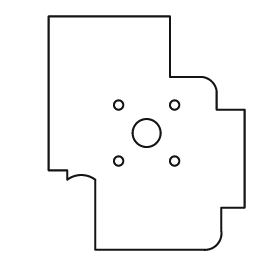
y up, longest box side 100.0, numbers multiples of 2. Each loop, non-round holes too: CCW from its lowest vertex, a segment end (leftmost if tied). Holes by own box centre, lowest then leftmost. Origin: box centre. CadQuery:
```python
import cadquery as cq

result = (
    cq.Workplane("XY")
    .moveTo(-22.0, -50.0)
    .lineTo(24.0, -50.0)
    .threePointArc((30.0, -48.0), (32.0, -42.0))
    .lineTo(32.0, -32.0)
    .lineTo(42.0, -32.0)
    .lineTo(42.0, 10.0)
    .lineTo(30.0, 10.0)
    .lineTo(30.0, 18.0)
    .threePointArc((28.0, 22.0), (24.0, 24.0))
    .lineTo(10.0, 24.0)
    .lineTo(10.0, 50.0)
    .lineTo(-42.0, 50.0)
    .lineTo(-42.0, -16.0)
    .lineTo(-34.0, -16.0)
    .lineTo(-34.0, -20.0)
    .threePointArc((-28.0, -18.0), (-22.0, -20.0))
    .close()
    .moveTo(-12.0, -12.0)
    .circle(2.0)
    .moveTo(12.0, -12.0)
    .circle(2.0)
    .moveTo(0.0, 0.0)
    .circle(6.0)
    .moveTo(-12.0, 12.0)
    .circle(2.0)
    .moveTo(12.0, 12.0)
    .circle(2.0)
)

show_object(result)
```